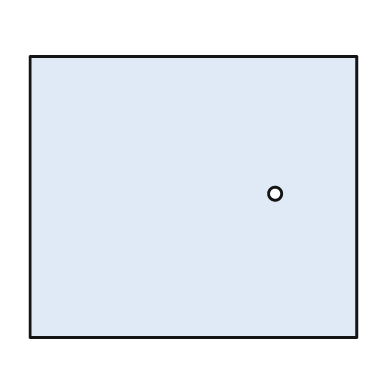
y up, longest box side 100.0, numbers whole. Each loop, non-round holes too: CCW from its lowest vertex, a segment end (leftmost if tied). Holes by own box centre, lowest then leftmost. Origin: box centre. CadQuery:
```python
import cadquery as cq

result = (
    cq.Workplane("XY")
    .moveTo(-50.0, -43.0)
    .lineTo(50.0, -43.0)
    .lineTo(50.0, 43.0)
    .lineTo(-50.0, 43.0)
    .close()
    .moveTo(25.0, 1.0)
    .circle(2.0)
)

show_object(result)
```